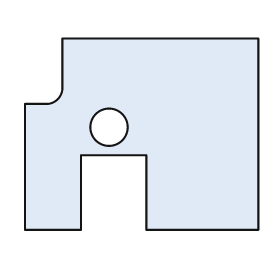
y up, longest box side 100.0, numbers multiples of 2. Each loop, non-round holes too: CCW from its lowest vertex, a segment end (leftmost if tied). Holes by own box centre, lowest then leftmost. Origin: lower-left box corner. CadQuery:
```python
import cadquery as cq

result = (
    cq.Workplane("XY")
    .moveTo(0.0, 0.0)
    .lineTo(24.0, 0.0)
    .lineTo(24.0, 32.0)
    .lineTo(52.0, 32.0)
    .lineTo(52.0, 0.0)
    .lineTo(100.0, 0.0)
    .lineTo(100.0, 82.0)
    .lineTo(16.0, 82.0)
    .lineTo(16.0, 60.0)
    .threePointArc((14.0, 56.0), (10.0, 54.0))
    .lineTo(0.0, 54.0)
    .close()
    .moveTo(36.0, 44.0)
    .circle(8.0)
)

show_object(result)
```